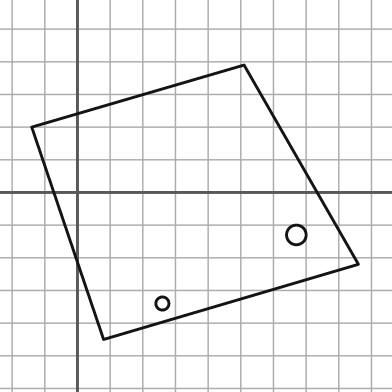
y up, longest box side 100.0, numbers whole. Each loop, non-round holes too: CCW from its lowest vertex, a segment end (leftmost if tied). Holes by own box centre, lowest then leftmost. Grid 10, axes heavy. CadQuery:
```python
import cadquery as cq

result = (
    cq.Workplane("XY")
    .moveTo(8.0, -45.0)
    .lineTo(86.0, -22.0)
    .lineTo(51.0, 39.0)
    .lineTo(-14.0, 20.0)
    .close()
    .moveTo(26.0, -34.0)
    .circle(2.0)
    .moveTo(67.0, -13.0)
    .circle(3.0)
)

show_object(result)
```